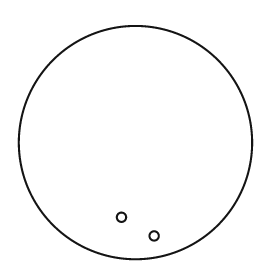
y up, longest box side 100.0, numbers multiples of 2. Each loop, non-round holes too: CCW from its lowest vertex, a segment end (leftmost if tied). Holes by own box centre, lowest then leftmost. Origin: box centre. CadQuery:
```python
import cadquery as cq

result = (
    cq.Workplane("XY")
    .moveTo(0.0, 0.0)
    .circle(50.0)
    .moveTo(8.0, -40.0)
    .circle(2.0)
    .moveTo(-6.0, -32.0)
    .circle(2.0)
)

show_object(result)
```